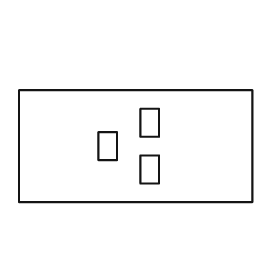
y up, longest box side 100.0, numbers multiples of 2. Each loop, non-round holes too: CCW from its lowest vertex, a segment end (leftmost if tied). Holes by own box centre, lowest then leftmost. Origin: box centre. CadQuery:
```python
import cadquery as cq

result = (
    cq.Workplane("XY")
    .moveTo(-50.0, -24.0)
    .lineTo(50.0, -24.0)
    .lineTo(50.0, 24.0)
    .lineTo(-50.0, 24.0)
    .close()
    .moveTo(2.0, -16.0)
    .lineTo(10.0, -16.0)
    .lineTo(10.0, -4.0)
    .lineTo(2.0, -4.0)
    .close()
    .moveTo(-16.0, -6.0)
    .lineTo(-8.0, -6.0)
    .lineTo(-8.0, 6.0)
    .lineTo(-16.0, 6.0)
    .close()
    .moveTo(2.0, 4.0)
    .lineTo(10.0, 4.0)
    .lineTo(10.0, 16.0)
    .lineTo(2.0, 16.0)
    .close()
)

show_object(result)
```